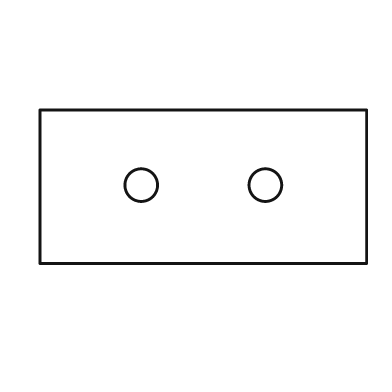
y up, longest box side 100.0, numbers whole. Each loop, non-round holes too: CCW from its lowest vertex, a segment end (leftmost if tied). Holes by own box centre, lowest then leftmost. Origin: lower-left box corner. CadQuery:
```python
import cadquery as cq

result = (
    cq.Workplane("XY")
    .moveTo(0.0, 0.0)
    .lineTo(100.0, 0.0)
    .lineTo(100.0, 47.0)
    .lineTo(0.0, 47.0)
    .close()
    .moveTo(31.0, 24.0)
    .circle(5.0)
    .moveTo(69.0, 24.0)
    .circle(5.0)
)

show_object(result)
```